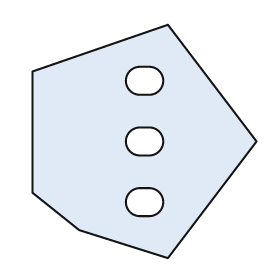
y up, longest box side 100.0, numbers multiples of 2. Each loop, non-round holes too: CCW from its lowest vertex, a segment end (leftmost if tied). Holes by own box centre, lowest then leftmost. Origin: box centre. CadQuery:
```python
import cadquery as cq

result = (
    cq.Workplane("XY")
    .moveTo(10.0, -50.0)
    .lineTo(48.0, 0.0)
    .lineTo(10.0, 50.0)
    .lineTo(-48.0, 30.0)
    .lineTo(-48.0, -22.0)
    .lineTo(-28.0, -38.0)
    .close()
    .moveTo(-2.0, -32.0)
    .lineTo(2.0, -32.0)
    .threePointArc((8.0, -26.0), (2.0, -20.0))
    .lineTo(-2.0, -20.0)
    .threePointArc((-8.0, -26.0), (-2.0, -32.0))
    .close()
    .moveTo(-2.0, -6.0)
    .lineTo(2.0, -6.0)
    .threePointArc((8.0, 0.0), (2.0, 6.0))
    .lineTo(-2.0, 6.0)
    .threePointArc((-8.0, 0.0), (-2.0, -6.0))
    .close()
    .moveTo(-2.0, 20.0)
    .lineTo(2.0, 20.0)
    .threePointArc((8.0, 26.0), (2.0, 32.0))
    .lineTo(-2.0, 32.0)
    .threePointArc((-8.0, 26.0), (-2.0, 20.0))
    .close()
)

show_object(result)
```